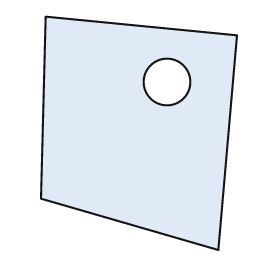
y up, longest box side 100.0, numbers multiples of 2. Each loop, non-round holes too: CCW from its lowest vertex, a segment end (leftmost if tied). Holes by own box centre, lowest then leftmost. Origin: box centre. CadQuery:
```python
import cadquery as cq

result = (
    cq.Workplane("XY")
    .moveTo(34.0, -50.0)
    .lineTo(42.0, 42.0)
    .lineTo(-40.0, 50.0)
    .lineTo(-42.0, -28.0)
    .close()
    .moveTo(12.0, 22.0)
    .circle(10.0)
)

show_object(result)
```